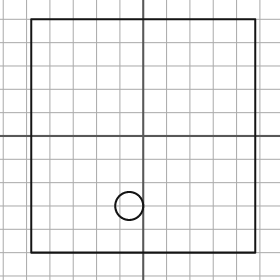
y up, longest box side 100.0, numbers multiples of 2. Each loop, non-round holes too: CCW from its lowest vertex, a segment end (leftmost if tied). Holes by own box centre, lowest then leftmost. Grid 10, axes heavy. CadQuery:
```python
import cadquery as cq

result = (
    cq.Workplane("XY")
    .moveTo(-48.0, -50.0)
    .lineTo(48.0, -50.0)
    .lineTo(48.0, 50.0)
    .lineTo(-48.0, 50.0)
    .close()
    .moveTo(-6.0, -30.0)
    .circle(6.0)
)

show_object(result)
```